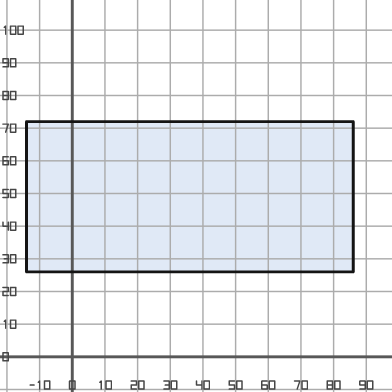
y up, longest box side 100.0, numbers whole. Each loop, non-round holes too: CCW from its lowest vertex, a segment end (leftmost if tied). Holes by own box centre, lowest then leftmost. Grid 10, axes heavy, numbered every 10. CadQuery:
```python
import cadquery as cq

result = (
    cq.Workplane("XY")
    .moveTo(-14.0, 26.0)
    .lineTo(86.0, 26.0)
    .lineTo(86.0, 72.0)
    .lineTo(-14.0, 72.0)
    .close()
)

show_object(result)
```